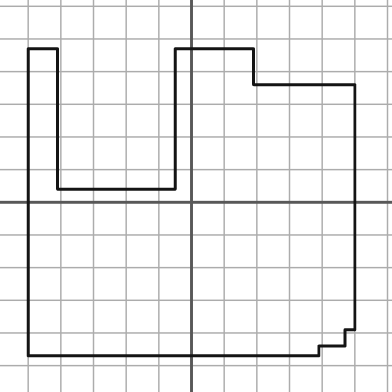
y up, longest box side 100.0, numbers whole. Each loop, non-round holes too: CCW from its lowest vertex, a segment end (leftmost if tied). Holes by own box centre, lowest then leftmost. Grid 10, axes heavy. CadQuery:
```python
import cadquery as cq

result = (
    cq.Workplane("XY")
    .moveTo(-50.0, -47.0)
    .lineTo(39.0, -47.0)
    .lineTo(39.0, -44.0)
    .lineTo(47.0, -44.0)
    .lineTo(47.0, -39.0)
    .lineTo(50.0, -39.0)
    .lineTo(50.0, 36.0)
    .lineTo(19.0, 36.0)
    .lineTo(19.0, 47.0)
    .lineTo(-5.0, 47.0)
    .lineTo(-5.0, 4.0)
    .lineTo(-41.0, 4.0)
    .lineTo(-41.0, 47.0)
    .lineTo(-50.0, 47.0)
    .close()
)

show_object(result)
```